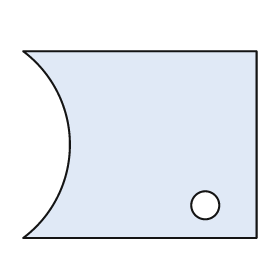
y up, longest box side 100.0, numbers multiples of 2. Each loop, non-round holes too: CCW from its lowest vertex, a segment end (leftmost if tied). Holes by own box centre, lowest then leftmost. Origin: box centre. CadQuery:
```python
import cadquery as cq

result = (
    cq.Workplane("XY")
    .moveTo(-50.0, -40.0)
    .lineTo(50.0, -40.0)
    .lineTo(50.0, 40.0)
    .lineTo(-50.0, 40.0)
    .threePointArc((-30.0, 0.0), (-50.0, -40.0))
    .close()
    .moveTo(28.0, -26.0)
    .circle(6.0)
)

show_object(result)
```